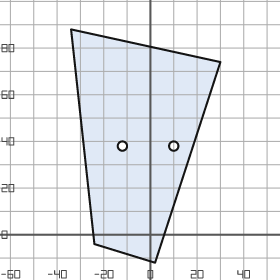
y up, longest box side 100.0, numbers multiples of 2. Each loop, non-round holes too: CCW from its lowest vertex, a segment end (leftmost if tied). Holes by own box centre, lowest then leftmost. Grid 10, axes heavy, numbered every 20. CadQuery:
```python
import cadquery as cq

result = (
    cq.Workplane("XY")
    .moveTo(2.0, -12.0)
    .lineTo(30.0, 74.0)
    .lineTo(-34.0, 88.0)
    .lineTo(-24.0, -4.0)
    .close()
    .moveTo(-12.0, 38.0)
    .circle(2.0)
    .moveTo(10.0, 38.0)
    .circle(2.0)
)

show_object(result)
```